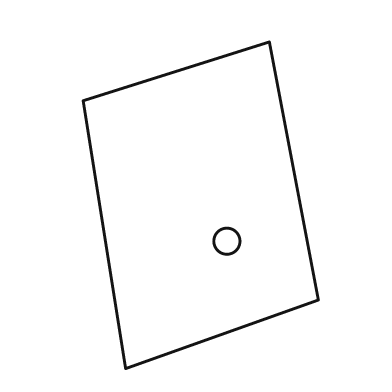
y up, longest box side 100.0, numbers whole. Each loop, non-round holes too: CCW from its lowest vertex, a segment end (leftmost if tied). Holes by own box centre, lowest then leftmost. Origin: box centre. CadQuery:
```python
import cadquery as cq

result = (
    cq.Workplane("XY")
    .moveTo(-23.0, -50.0)
    .lineTo(36.0, -29.0)
    .lineTo(21.0, 50.0)
    .lineTo(-36.0, 32.0)
    .close()
    .moveTo(8.0, -11.0)
    .circle(4.0)
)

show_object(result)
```